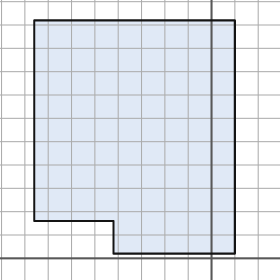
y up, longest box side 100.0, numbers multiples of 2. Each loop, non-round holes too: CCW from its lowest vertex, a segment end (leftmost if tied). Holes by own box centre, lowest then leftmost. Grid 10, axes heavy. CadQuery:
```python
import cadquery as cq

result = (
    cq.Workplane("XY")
    .moveTo(-42.0, 2.0)
    .lineTo(10.0, 2.0)
    .lineTo(10.0, 102.0)
    .lineTo(-76.0, 102.0)
    .lineTo(-76.0, 16.0)
    .lineTo(-42.0, 16.0)
    .close()
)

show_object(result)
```